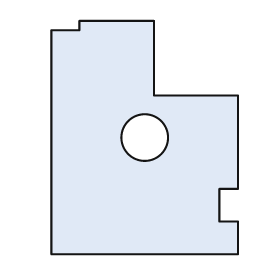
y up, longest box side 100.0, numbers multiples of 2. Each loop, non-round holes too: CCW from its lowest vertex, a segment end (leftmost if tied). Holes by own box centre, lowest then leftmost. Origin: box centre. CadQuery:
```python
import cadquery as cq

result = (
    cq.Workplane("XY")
    .moveTo(-40.0, -50.0)
    .lineTo(40.0, -50.0)
    .lineTo(40.0, -36.0)
    .lineTo(32.0, -36.0)
    .lineTo(32.0, -22.0)
    .lineTo(40.0, -22.0)
    .lineTo(40.0, 18.0)
    .lineTo(4.0, 18.0)
    .lineTo(4.0, 50.0)
    .lineTo(-28.0, 50.0)
    .lineTo(-28.0, 46.0)
    .lineTo(-40.0, 46.0)
    .close()
    .moveTo(0.0, 0.0)
    .circle(10.0)
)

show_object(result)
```